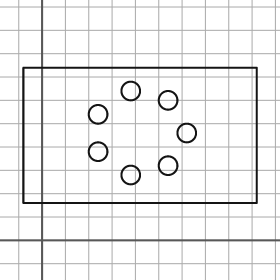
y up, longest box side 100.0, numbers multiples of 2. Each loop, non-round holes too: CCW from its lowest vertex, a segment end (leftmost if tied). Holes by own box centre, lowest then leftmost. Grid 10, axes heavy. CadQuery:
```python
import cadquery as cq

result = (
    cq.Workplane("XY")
    .moveTo(-8.0, 16.0)
    .lineTo(92.0, 16.0)
    .lineTo(92.0, 74.0)
    .lineTo(-8.0, 74.0)
    .close()
    .moveTo(38.0, 28.0)
    .circle(4.0)
    .moveTo(54.0, 32.0)
    .circle(4.0)
    .moveTo(24.0, 38.0)
    .circle(4.0)
    .moveTo(62.0, 46.0)
    .circle(4.0)
    .moveTo(24.0, 54.0)
    .circle(4.0)
    .moveTo(54.0, 60.0)
    .circle(4.0)
    .moveTo(38.0, 64.0)
    .circle(4.0)
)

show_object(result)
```